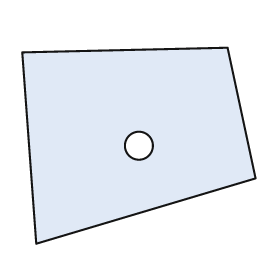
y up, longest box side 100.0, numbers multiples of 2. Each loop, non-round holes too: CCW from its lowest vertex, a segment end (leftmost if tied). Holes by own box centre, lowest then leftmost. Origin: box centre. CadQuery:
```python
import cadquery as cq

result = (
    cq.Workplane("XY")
    .moveTo(-44.0, -42.0)
    .lineTo(50.0, -14.0)
    .lineTo(38.0, 42.0)
    .lineTo(-50.0, 40.0)
    .close()
    .moveTo(0.0, 0.0)
    .circle(6.0)
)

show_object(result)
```